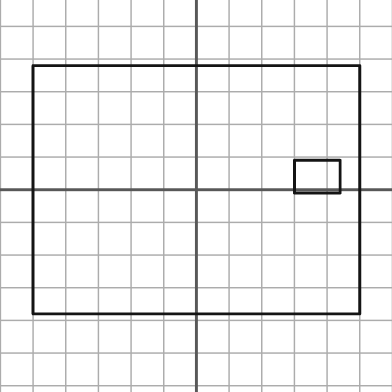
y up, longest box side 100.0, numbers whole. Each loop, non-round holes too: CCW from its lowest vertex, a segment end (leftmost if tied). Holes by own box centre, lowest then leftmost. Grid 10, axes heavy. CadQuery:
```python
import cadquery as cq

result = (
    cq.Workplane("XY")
    .moveTo(-50.0, -38.0)
    .lineTo(50.0, -38.0)
    .lineTo(50.0, 38.0)
    .lineTo(-50.0, 38.0)
    .close()
    .moveTo(30.0, -1.0)
    .lineTo(44.0, -1.0)
    .lineTo(44.0, 9.0)
    .lineTo(30.0, 9.0)
    .close()
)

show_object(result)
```